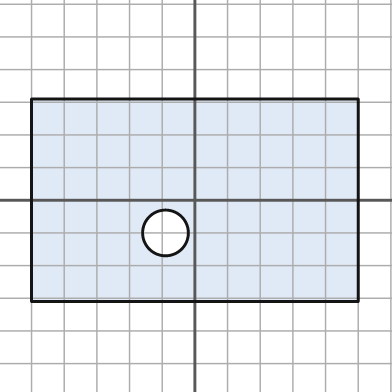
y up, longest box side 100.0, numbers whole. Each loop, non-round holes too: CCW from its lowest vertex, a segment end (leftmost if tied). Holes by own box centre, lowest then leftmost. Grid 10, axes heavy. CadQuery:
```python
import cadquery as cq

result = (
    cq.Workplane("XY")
    .moveTo(-50.0, -31.0)
    .lineTo(50.0, -31.0)
    .lineTo(50.0, 31.0)
    .lineTo(-50.0, 31.0)
    .close()
    .moveTo(-9.0, -10.0)
    .circle(7.0)
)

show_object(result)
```